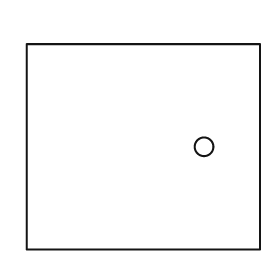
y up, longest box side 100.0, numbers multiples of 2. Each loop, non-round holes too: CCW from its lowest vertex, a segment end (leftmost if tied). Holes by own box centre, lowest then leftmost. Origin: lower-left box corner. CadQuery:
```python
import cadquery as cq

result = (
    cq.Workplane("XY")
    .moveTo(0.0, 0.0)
    .lineTo(100.0, 0.0)
    .lineTo(100.0, 88.0)
    .lineTo(0.0, 88.0)
    .close()
    .moveTo(76.0, 44.0)
    .circle(4.0)
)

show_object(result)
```